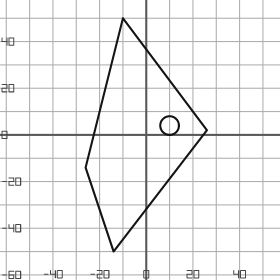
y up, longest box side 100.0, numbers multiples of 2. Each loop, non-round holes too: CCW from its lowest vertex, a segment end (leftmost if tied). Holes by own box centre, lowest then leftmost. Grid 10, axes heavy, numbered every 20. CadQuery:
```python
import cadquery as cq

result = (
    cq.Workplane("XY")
    .moveTo(-14.0, -50.0)
    .lineTo(26.0, 2.0)
    .lineTo(-10.0, 50.0)
    .lineTo(-26.0, -14.0)
    .close()
    .moveTo(10.0, 4.0)
    .circle(4.0)
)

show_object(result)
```